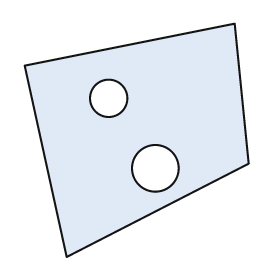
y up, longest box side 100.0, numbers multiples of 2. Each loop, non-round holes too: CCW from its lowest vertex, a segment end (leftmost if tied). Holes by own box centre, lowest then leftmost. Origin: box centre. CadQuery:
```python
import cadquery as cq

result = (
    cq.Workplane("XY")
    .moveTo(-30.0, -50.0)
    .lineTo(48.0, -10.0)
    .lineTo(42.0, 50.0)
    .lineTo(-48.0, 32.0)
    .close()
    .moveTo(8.0, -12.0)
    .circle(10.0)
    .moveTo(-12.0, 18.0)
    .circle(8.0)
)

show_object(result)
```